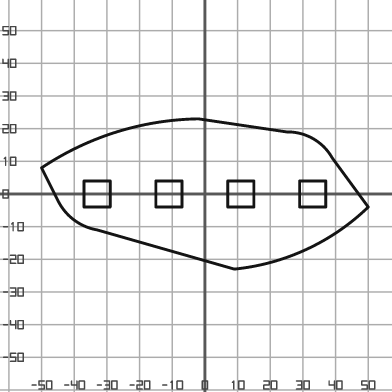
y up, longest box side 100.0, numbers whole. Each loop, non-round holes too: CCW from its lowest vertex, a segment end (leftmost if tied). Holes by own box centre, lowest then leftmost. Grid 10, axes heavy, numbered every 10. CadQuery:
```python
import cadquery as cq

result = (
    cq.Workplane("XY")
    .moveTo(9.0, -23.0)
    .threePointArc((31.0, -17.0), (50.0, -4.0))
    .lineTo(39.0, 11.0)
    .threePointArc((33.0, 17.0), (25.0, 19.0))
    .lineTo(-2.0, 23.0)
    .threePointArc((-27.0, 19.0), (-50.0, 8.0))
    .lineTo(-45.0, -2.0)
    .threePointArc((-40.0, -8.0), (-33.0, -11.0))
    .close()
    .moveTo(-37.0, -4.0)
    .lineTo(-29.0, -4.0)
    .lineTo(-29.0, 4.0)
    .lineTo(-37.0, 4.0)
    .close()
    .moveTo(-15.0, -4.0)
    .lineTo(-7.0, -4.0)
    .lineTo(-7.0, 4.0)
    .lineTo(-15.0, 4.0)
    .close()
    .moveTo(7.0, -4.0)
    .lineTo(15.0, -4.0)
    .lineTo(15.0, 4.0)
    .lineTo(7.0, 4.0)
    .close()
    .moveTo(29.0, -4.0)
    .lineTo(37.0, -4.0)
    .lineTo(37.0, 4.0)
    .lineTo(29.0, 4.0)
    .close()
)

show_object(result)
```